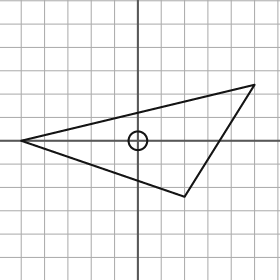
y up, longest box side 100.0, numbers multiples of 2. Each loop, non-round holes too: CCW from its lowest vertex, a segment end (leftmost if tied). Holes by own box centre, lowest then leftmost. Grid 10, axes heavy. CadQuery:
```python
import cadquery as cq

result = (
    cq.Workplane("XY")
    .moveTo(20.0, -24.0)
    .lineTo(50.0, 24.0)
    .lineTo(-50.0, 0.0)
    .close()
    .moveTo(0.0, 0.0)
    .circle(4.0)
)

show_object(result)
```